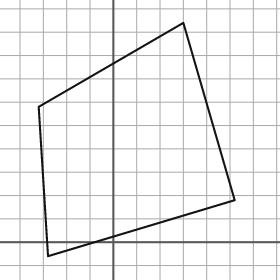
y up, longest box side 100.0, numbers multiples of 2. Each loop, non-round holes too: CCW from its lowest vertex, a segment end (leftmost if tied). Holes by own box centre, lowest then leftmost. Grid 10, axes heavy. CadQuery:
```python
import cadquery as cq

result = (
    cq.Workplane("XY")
    .moveTo(-28.0, -6.0)
    .lineTo(52.0, 18.0)
    .lineTo(30.0, 94.0)
    .lineTo(-32.0, 58.0)
    .close()
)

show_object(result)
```